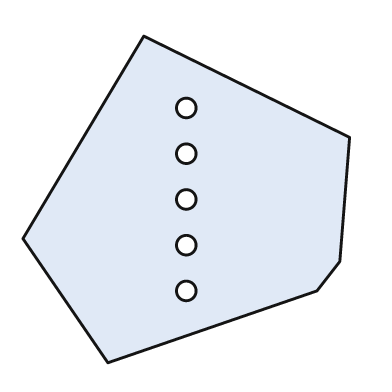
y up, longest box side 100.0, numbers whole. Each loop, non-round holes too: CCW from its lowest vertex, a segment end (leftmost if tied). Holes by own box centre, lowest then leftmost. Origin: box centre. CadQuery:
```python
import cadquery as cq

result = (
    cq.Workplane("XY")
    .moveTo(-24.0, -50.0)
    .lineTo(40.0, -28.0)
    .lineTo(47.0, -19.0)
    .lineTo(50.0, 19.0)
    .lineTo(-13.0, 50.0)
    .lineTo(-50.0, -12.0)
    .close()
    .moveTo(0.0, -28.0)
    .circle(3.0)
    .moveTo(0.0, -14.0)
    .circle(3.0)
    .moveTo(0.0, 0.0)
    .circle(3.0)
    .moveTo(0.0, 14.0)
    .circle(3.0)
    .moveTo(0.0, 28.0)
    .circle(3.0)
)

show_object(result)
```